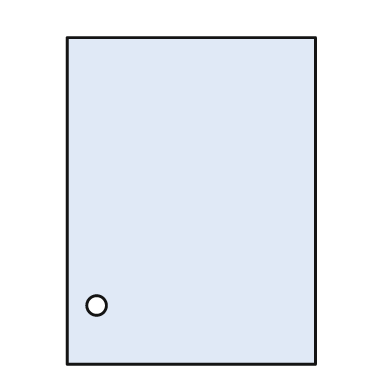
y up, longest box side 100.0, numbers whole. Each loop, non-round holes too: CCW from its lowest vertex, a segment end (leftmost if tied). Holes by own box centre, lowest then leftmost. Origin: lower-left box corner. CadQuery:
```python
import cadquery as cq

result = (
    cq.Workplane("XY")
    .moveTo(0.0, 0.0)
    .lineTo(76.0, 0.0)
    .lineTo(76.0, 100.0)
    .lineTo(0.0, 100.0)
    .close()
    .moveTo(9.0, 18.0)
    .circle(3.0)
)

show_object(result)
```